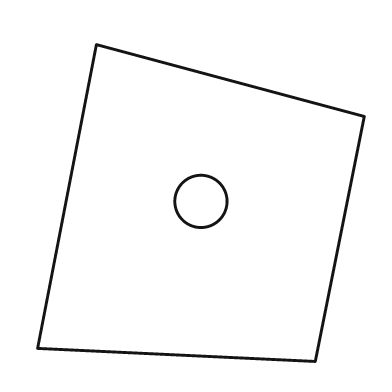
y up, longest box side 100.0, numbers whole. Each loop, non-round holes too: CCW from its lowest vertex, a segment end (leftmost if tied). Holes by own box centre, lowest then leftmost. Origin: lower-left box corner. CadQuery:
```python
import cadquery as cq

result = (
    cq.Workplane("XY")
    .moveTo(85.0, 0.0)
    .lineTo(100.0, 75.0)
    .lineTo(18.0, 97.0)
    .lineTo(0.0, 4.0)
    .close()
    .moveTo(50.0, 49.0)
    .circle(8.0)
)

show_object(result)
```